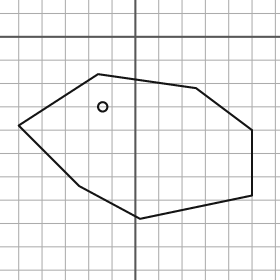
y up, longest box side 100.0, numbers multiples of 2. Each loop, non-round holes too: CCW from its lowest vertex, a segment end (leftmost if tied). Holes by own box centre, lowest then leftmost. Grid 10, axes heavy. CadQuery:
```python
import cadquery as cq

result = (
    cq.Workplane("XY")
    .moveTo(2.0, -78.0)
    .lineTo(50.0, -68.0)
    .lineTo(50.0, -40.0)
    .lineTo(26.0, -22.0)
    .lineTo(-16.0, -16.0)
    .lineTo(-50.0, -38.0)
    .lineTo(-24.0, -64.0)
    .close()
    .moveTo(-14.0, -30.0)
    .circle(2.0)
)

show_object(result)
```